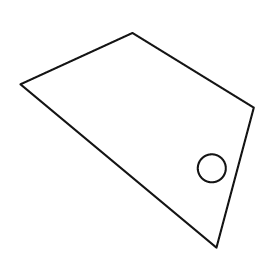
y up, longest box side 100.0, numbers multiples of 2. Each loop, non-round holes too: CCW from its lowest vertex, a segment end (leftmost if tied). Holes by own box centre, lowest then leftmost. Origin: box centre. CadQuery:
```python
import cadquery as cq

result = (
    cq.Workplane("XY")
    .moveTo(34.0, -46.0)
    .lineTo(50.0, 14.0)
    .lineTo(-2.0, 46.0)
    .lineTo(-50.0, 24.0)
    .close()
    .moveTo(32.0, -12.0)
    .circle(6.0)
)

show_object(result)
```